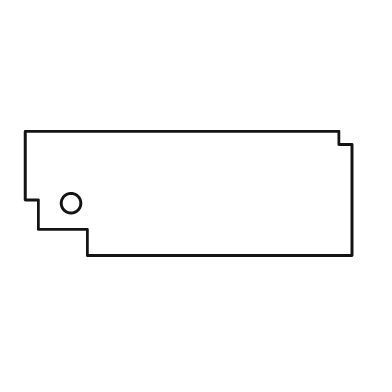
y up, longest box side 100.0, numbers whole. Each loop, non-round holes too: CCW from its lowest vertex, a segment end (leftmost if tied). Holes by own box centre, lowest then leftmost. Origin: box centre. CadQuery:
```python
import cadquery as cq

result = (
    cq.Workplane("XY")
    .moveTo(-31.0, -19.0)
    .lineTo(50.0, -19.0)
    .lineTo(50.0, 15.0)
    .lineTo(46.0, 15.0)
    .lineTo(46.0, 19.0)
    .lineTo(-50.0, 19.0)
    .lineTo(-50.0, -2.0)
    .lineTo(-46.0, -2.0)
    .lineTo(-46.0, -11.0)
    .lineTo(-31.0, -11.0)
    .close()
    .moveTo(-36.0, -3.0)
    .circle(3.0)
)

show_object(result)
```